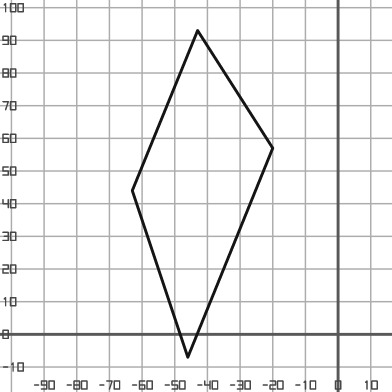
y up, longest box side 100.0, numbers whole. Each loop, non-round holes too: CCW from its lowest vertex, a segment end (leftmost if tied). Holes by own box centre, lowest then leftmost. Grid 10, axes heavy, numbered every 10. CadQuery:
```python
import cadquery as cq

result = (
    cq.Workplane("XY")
    .moveTo(-46.0, -7.0)
    .lineTo(-20.0, 57.0)
    .lineTo(-43.0, 93.0)
    .lineTo(-63.0, 44.0)
    .close()
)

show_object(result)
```